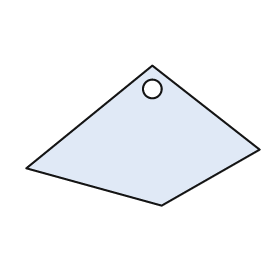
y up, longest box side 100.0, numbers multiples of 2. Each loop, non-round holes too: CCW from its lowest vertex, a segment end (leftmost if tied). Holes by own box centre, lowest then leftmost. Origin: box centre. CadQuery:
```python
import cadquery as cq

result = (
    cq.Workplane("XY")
    .moveTo(8.0, -30.0)
    .lineTo(50.0, -6.0)
    .lineTo(4.0, 30.0)
    .lineTo(-50.0, -14.0)
    .close()
    .moveTo(4.0, 20.0)
    .circle(4.0)
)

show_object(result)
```